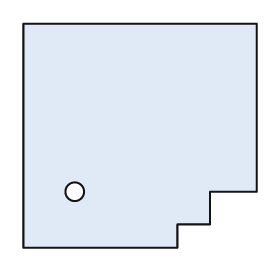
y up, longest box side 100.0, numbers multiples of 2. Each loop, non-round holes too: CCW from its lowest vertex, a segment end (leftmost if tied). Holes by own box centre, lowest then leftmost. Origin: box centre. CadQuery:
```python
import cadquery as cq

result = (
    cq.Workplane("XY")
    .moveTo(-50.0, -48.0)
    .lineTo(16.0, -48.0)
    .lineTo(16.0, -38.0)
    .lineTo(30.0, -38.0)
    .lineTo(30.0, -24.0)
    .lineTo(50.0, -24.0)
    .lineTo(50.0, 48.0)
    .lineTo(-50.0, 48.0)
    .close()
    .moveTo(-28.0, -24.0)
    .circle(4.0)
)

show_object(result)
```